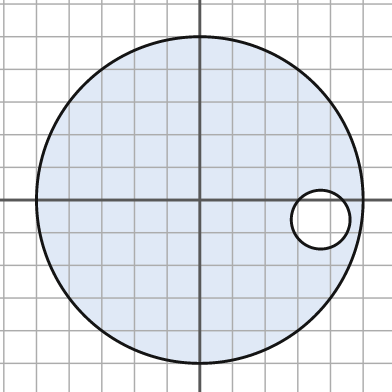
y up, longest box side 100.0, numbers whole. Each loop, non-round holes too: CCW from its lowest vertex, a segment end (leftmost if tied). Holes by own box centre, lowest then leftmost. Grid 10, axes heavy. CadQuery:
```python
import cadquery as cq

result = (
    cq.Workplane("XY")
    .moveTo(0.0, 0.0)
    .circle(50.0)
    .moveTo(37.0, -6.0)
    .circle(9.0)
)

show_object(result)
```